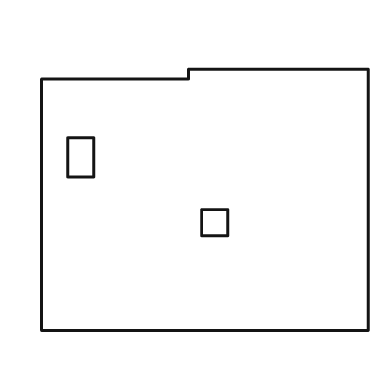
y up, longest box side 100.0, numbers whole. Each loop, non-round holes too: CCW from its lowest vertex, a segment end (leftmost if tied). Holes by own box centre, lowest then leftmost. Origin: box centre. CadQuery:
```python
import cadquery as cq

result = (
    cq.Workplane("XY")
    .moveTo(-50.0, -40.0)
    .lineTo(50.0, -40.0)
    .lineTo(50.0, 40.0)
    .lineTo(-5.0, 40.0)
    .lineTo(-5.0, 37.0)
    .lineTo(-50.0, 37.0)
    .close()
    .moveTo(-1.0, -11.0)
    .lineTo(7.0, -11.0)
    .lineTo(7.0, -3.0)
    .lineTo(-1.0, -3.0)
    .close()
    .moveTo(-42.0, 7.0)
    .lineTo(-34.0, 7.0)
    .lineTo(-34.0, 19.0)
    .lineTo(-42.0, 19.0)
    .close()
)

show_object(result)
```